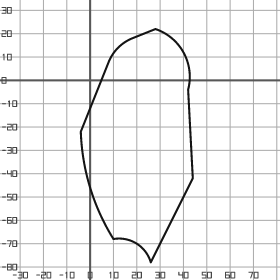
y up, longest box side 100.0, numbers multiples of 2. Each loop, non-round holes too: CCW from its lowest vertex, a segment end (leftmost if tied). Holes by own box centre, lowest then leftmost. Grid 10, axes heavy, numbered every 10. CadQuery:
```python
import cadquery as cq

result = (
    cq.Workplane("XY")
    .moveTo(26.0, -78.0)
    .lineTo(44.0, -42.0)
    .lineTo(42.0, -4.0)
    .threePointArc((40.0, 12.0), (28.0, 22.0))
    .lineTo(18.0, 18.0)
    .threePointArc((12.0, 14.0), (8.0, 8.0))
    .lineTo(-4.0, -22.0)
    .threePointArc((0.0, -46.0), (10.0, -68.0))
    .threePointArc((20.0, -70.0), (26.0, -78.0))
    .close()
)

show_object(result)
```